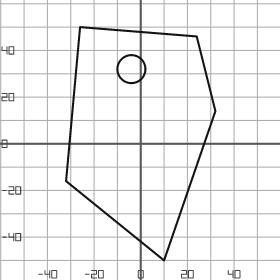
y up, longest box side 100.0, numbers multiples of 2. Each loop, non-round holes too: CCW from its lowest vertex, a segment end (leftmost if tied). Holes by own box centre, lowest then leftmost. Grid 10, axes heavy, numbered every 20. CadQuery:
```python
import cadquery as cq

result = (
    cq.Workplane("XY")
    .moveTo(10.0, -50.0)
    .lineTo(32.0, 14.0)
    .lineTo(24.0, 46.0)
    .lineTo(-26.0, 50.0)
    .lineTo(-32.0, -16.0)
    .close()
    .moveTo(-4.0, 32.0)
    .circle(6.0)
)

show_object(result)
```